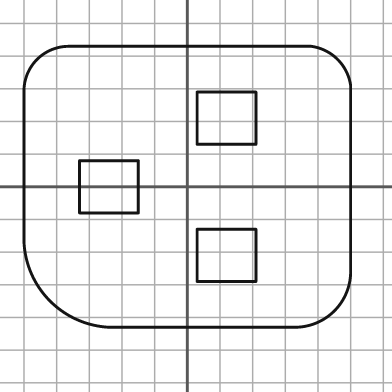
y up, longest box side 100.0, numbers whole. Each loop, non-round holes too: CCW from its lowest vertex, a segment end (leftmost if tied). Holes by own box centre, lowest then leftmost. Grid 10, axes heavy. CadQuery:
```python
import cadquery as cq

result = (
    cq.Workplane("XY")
    .moveTo(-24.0, -43.0)
    .lineTo(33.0, -43.0)
    .threePointArc((45.0, -38.0), (50.0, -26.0))
    .lineTo(50.0, 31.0)
    .threePointArc((46.0, 39.0), (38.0, 43.0))
    .lineTo(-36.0, 43.0)
    .threePointArc((-46.0, 39.0), (-50.0, 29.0))
    .lineTo(-50.0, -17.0)
    .threePointArc((-42.0, -35.0), (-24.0, -43.0))
    .close()
    .moveTo(3.0, -29.0)
    .lineTo(21.0, -29.0)
    .lineTo(21.0, -13.0)
    .lineTo(3.0, -13.0)
    .close()
    .moveTo(-33.0, -8.0)
    .lineTo(-15.0, -8.0)
    .lineTo(-15.0, 8.0)
    .lineTo(-33.0, 8.0)
    .close()
    .moveTo(3.0, 13.0)
    .lineTo(21.0, 13.0)
    .lineTo(21.0, 29.0)
    .lineTo(3.0, 29.0)
    .close()
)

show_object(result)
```